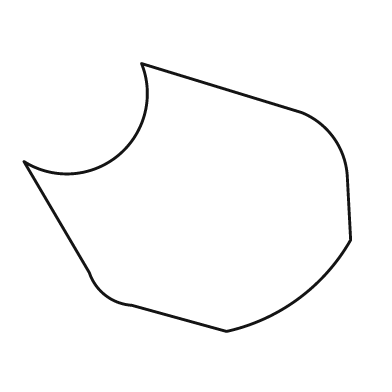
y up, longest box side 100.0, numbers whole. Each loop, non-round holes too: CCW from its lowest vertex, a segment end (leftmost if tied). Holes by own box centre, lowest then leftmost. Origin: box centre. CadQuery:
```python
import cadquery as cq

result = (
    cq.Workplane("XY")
    .moveTo(12.0, -41.0)
    .threePointArc((34.0, -31.0), (50.0, -13.0))
    .lineTo(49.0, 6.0)
    .threePointArc((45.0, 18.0), (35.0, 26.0))
    .lineTo(-14.0, 41.0)
    .threePointArc((-21.0, 13.0), (-50.0, 11.0))
    .lineTo(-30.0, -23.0)
    .threePointArc((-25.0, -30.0), (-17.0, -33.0))
    .close()
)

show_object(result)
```